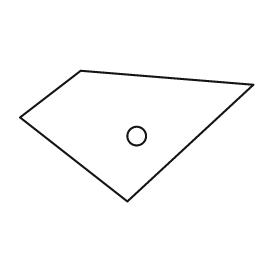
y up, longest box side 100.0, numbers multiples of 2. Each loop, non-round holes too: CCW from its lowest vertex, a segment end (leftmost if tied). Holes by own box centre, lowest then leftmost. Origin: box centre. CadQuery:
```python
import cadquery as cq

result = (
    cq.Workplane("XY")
    .moveTo(-4.0, -28.0)
    .lineTo(50.0, 22.0)
    .lineTo(-24.0, 28.0)
    .lineTo(-50.0, 8.0)
    .close()
    .moveTo(0.0, 0.0)
    .circle(4.0)
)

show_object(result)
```